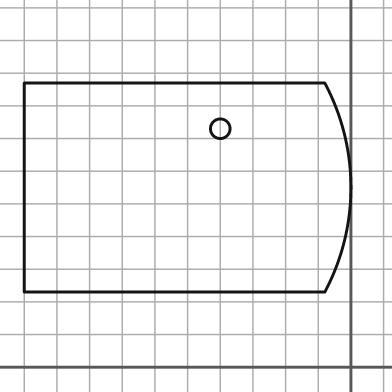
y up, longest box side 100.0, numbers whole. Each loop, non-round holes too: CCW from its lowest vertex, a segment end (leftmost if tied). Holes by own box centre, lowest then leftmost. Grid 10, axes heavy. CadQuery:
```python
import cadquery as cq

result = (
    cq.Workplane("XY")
    .moveTo(-100.0, 23.0)
    .lineTo(-8.0, 23.0)
    .threePointArc((0.0, 55.0), (-8.0, 87.0))
    .lineTo(-100.0, 87.0)
    .close()
    .moveTo(-40.0, 73.0)
    .circle(3.0)
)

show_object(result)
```